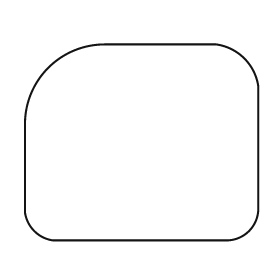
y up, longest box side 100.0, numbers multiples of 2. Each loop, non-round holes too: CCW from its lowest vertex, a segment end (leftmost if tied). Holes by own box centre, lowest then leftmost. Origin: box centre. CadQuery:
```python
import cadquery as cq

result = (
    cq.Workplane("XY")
    .moveTo(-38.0, -42.0)
    .lineTo(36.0, -42.0)
    .threePointArc((46.0, -38.0), (50.0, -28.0))
    .lineTo(50.0, 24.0)
    .threePointArc((44.0, 36.0), (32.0, 42.0))
    .lineTo(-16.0, 42.0)
    .threePointArc((-40.0, 32.0), (-50.0, 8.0))
    .lineTo(-50.0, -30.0)
    .threePointArc((-46.0, -38.0), (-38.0, -42.0))
    .close()
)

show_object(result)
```